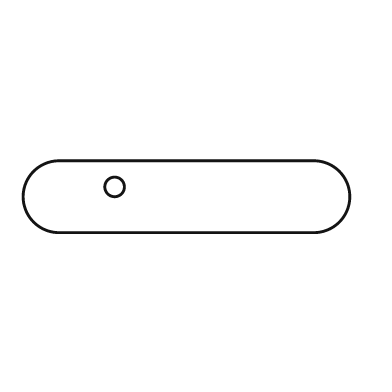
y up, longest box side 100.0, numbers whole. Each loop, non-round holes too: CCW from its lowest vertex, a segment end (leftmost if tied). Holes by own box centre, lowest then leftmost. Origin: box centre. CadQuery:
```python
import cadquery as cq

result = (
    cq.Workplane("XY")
    .moveTo(-39.0, -11.0)
    .lineTo(39.0, -11.0)
    .threePointArc((50.0, 0.0), (39.0, 11.0))
    .lineTo(-39.0, 11.0)
    .threePointArc((-50.0, 0.0), (-39.0, -11.0))
    .close()
    .moveTo(-22.0, 3.0)
    .circle(3.0)
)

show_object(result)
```